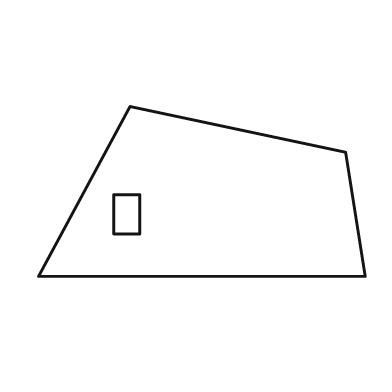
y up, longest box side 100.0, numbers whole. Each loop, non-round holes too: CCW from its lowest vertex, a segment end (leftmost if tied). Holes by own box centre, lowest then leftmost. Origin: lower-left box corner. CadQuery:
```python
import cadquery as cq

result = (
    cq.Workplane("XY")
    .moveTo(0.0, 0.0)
    .lineTo(100.0, 0.0)
    .lineTo(94.0, 38.0)
    .lineTo(28.0, 52.0)
    .close()
    .moveTo(23.0, 13.0)
    .lineTo(31.0, 13.0)
    .lineTo(31.0, 25.0)
    .lineTo(23.0, 25.0)
    .close()
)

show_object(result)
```